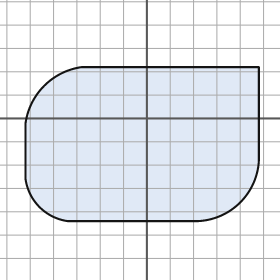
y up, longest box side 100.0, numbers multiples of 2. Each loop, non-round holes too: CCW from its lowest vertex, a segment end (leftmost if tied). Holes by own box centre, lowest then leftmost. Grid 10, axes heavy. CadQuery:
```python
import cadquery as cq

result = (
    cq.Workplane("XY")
    .moveTo(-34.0, -44.0)
    .lineTo(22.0, -44.0)
    .threePointArc((40.0, -36.0), (48.0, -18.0))
    .lineTo(48.0, 22.0)
    .lineTo(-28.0, 22.0)
    .threePointArc((-44.0, 14.0), (-52.0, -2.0))
    .lineTo(-52.0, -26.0)
    .threePointArc((-46.0, -38.0), (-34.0, -44.0))
    .close()
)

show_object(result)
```